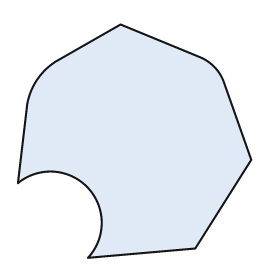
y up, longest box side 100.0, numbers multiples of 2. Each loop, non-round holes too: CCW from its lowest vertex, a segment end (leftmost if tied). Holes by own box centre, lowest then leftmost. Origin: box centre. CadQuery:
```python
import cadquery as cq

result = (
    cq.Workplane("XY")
    .moveTo(-20.0, -50.0)
    .lineTo(26.0, -46.0)
    .lineTo(50.0, -8.0)
    .lineTo(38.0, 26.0)
    .threePointArc((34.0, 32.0), (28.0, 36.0))
    .lineTo(-6.0, 50.0)
    .lineTo(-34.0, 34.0)
    .threePointArc((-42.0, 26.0), (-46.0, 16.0))
    .lineTo(-50.0, -18.0)
    .threePointArc((-20.0, -20.0), (-20.0, -50.0))
    .close()
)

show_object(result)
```